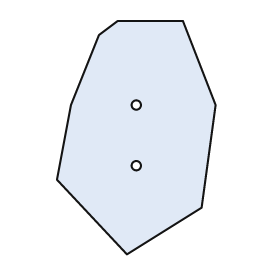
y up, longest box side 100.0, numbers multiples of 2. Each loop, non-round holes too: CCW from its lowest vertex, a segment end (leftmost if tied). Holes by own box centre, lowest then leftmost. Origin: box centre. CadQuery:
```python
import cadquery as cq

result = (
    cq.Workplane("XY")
    .moveTo(-4.0, -50.0)
    .lineTo(28.0, -30.0)
    .lineTo(34.0, 14.0)
    .lineTo(20.0, 50.0)
    .lineTo(-8.0, 50.0)
    .lineTo(-16.0, 44.0)
    .lineTo(-28.0, 14.0)
    .lineTo(-34.0, -18.0)
    .close()
    .moveTo(0.0, -12.0)
    .circle(2.0)
    .moveTo(0.0, 14.0)
    .circle(2.0)
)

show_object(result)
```